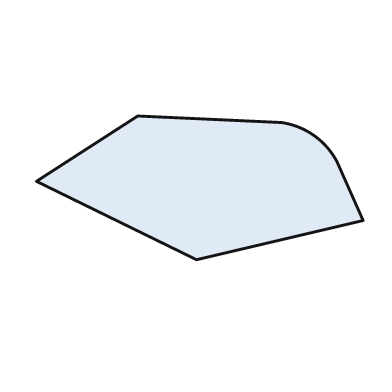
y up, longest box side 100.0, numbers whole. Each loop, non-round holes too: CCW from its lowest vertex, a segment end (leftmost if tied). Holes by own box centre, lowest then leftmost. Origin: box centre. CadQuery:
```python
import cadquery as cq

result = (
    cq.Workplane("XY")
    .moveTo(-1.0, -22.0)
    .lineTo(50.0, -10.0)
    .lineTo(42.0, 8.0)
    .threePointArc((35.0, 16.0), (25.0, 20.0))
    .lineTo(-19.0, 22.0)
    .lineTo(-50.0, 2.0)
    .close()
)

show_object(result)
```